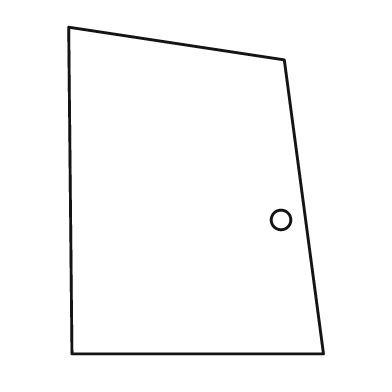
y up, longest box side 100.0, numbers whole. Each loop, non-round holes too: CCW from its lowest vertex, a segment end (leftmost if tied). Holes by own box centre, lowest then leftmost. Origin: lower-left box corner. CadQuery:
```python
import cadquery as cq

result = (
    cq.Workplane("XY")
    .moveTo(1.0, 0.0)
    .lineTo(78.0, 0.0)
    .lineTo(66.0, 90.0)
    .lineTo(0.0, 100.0)
    .close()
    .moveTo(65.0, 41.0)
    .circle(3.0)
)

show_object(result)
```